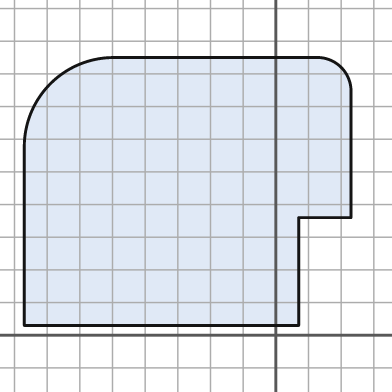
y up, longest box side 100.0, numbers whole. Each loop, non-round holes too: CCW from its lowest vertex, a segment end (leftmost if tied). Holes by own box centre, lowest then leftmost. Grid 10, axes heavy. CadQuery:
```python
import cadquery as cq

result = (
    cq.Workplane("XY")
    .moveTo(-77.0, 3.0)
    .lineTo(7.0, 3.0)
    .lineTo(7.0, 36.0)
    .lineTo(23.0, 36.0)
    .lineTo(23.0, 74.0)
    .threePointArc((20.0, 82.0), (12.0, 85.0))
    .lineTo(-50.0, 85.0)
    .threePointArc((-69.0, 77.0), (-77.0, 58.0))
    .close()
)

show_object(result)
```